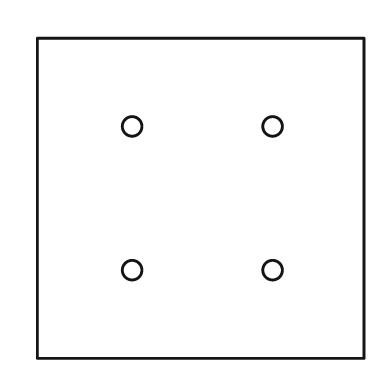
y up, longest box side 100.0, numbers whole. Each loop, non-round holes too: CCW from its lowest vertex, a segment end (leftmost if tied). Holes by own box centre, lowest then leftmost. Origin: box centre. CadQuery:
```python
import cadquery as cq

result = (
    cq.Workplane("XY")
    .moveTo(-50.0, -49.0)
    .lineTo(50.0, -49.0)
    .lineTo(50.0, 49.0)
    .lineTo(-50.0, 49.0)
    .close()
    .moveTo(-21.0, -22.0)
    .circle(3.0)
    .moveTo(22.0, -22.0)
    .circle(3.0)
    .moveTo(-21.0, 22.0)
    .circle(3.0)
    .moveTo(22.0, 22.0)
    .circle(3.0)
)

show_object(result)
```